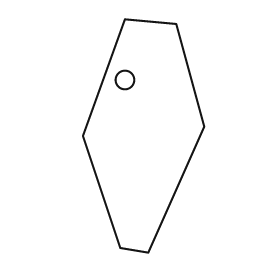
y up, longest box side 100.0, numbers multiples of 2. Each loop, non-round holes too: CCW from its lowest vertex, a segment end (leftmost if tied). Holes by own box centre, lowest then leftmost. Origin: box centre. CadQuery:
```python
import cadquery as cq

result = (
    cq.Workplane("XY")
    .moveTo(2.0, -50.0)
    .lineTo(26.0, 4.0)
    .lineTo(14.0, 48.0)
    .lineTo(-8.0, 50.0)
    .lineTo(-26.0, 0.0)
    .lineTo(-10.0, -48.0)
    .close()
    .moveTo(-8.0, 24.0)
    .circle(4.0)
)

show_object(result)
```